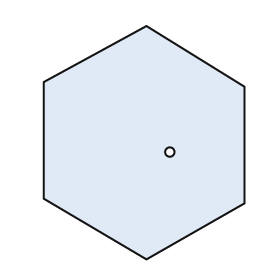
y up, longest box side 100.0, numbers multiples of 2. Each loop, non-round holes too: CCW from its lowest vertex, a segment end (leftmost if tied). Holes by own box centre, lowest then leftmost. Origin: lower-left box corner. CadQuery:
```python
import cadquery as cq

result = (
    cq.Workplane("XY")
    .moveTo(44.0, 0.0)
    .lineTo(86.0, 24.0)
    .lineTo(86.0, 74.0)
    .lineTo(44.0, 100.0)
    .lineTo(0.0, 76.0)
    .lineTo(0.0, 26.0)
    .close()
    .moveTo(54.0, 46.0)
    .circle(2.0)
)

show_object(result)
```